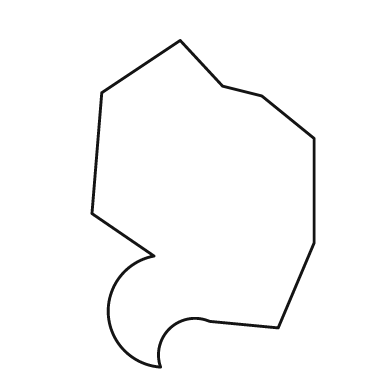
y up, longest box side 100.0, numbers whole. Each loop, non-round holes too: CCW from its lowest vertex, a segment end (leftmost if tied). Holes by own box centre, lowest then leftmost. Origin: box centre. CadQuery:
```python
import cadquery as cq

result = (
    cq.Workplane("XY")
    .moveTo(-13.0, -50.0)
    .threePointArc((-10.0, -38.0), (2.0, -36.0))
    .lineTo(23.0, -38.0)
    .lineTo(34.0, -12.0)
    .lineTo(34.0, 20.0)
    .lineTo(18.0, 33.0)
    .lineTo(6.0, 36.0)
    .lineTo(-7.0, 50.0)
    .lineTo(-31.0, 34.0)
    .lineTo(-34.0, -3.0)
    .lineTo(-15.0, -16.0)
    .threePointArc((-29.0, -34.0), (-13.0, -50.0))
    .close()
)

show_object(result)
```